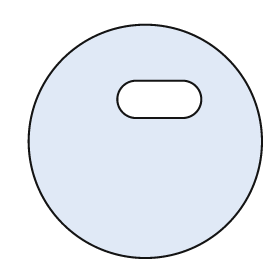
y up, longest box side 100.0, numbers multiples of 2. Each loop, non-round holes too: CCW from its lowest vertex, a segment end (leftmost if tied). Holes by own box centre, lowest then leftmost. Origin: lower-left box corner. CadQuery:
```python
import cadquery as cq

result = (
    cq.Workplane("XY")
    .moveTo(50.0, 50.0)
    .circle(50.0)
    .moveTo(46.0, 60.0)
    .lineTo(66.0, 60.0)
    .threePointArc((74.0, 68.0), (66.0, 76.0))
    .lineTo(46.0, 76.0)
    .threePointArc((38.0, 68.0), (46.0, 60.0))
    .close()
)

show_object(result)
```